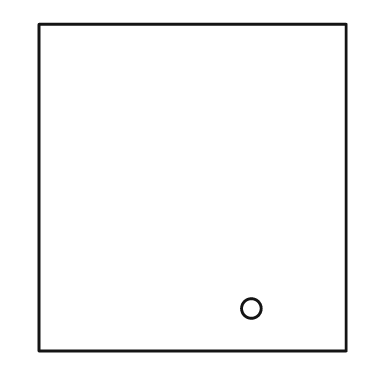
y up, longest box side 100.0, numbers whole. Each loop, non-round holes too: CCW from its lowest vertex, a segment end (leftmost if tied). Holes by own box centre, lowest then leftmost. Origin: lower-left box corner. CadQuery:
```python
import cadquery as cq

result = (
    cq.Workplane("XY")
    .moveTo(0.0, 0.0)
    .lineTo(94.0, 0.0)
    .lineTo(94.0, 100.0)
    .lineTo(0.0, 100.0)
    .close()
    .moveTo(65.0, 13.0)
    .circle(3.0)
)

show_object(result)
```